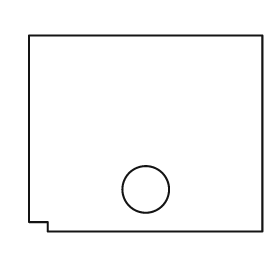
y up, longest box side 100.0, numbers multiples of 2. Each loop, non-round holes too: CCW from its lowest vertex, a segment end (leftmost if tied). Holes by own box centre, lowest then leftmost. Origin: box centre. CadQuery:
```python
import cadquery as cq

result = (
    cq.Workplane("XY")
    .moveTo(-42.0, -42.0)
    .lineTo(50.0, -42.0)
    .lineTo(50.0, 42.0)
    .lineTo(-50.0, 42.0)
    .lineTo(-50.0, -38.0)
    .lineTo(-42.0, -38.0)
    .close()
    .moveTo(0.0, -24.0)
    .circle(10.0)
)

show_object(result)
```